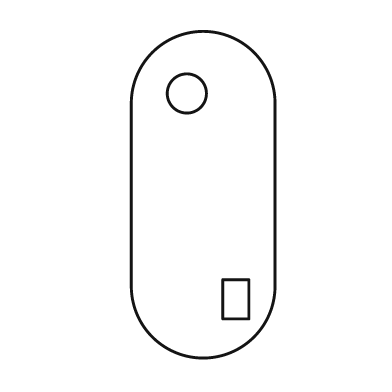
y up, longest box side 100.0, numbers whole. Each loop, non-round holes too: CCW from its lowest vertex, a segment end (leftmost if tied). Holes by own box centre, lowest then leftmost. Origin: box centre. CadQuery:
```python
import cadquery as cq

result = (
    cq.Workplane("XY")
    .moveTo(-22.0, -28.0)
    .threePointArc((0.0, -50.0), (22.0, -28.0))
    .lineTo(22.0, 28.0)
    .threePointArc((0.0, 50.0), (-22.0, 28.0))
    .close()
    .moveTo(6.0, -38.0)
    .lineTo(14.0, -38.0)
    .lineTo(14.0, -26.0)
    .lineTo(6.0, -26.0)
    .close()
    .moveTo(-5.0, 31.0)
    .circle(6.0)
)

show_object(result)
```